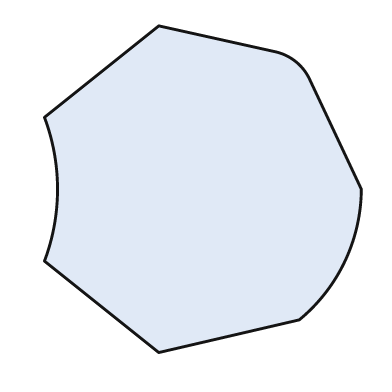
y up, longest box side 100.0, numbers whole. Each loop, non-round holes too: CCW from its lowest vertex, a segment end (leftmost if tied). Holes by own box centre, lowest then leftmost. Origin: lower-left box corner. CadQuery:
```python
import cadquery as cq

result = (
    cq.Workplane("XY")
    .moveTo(35.0, 0.0)
    .lineTo(78.0, 10.0)
    .threePointArc((92.0, 28.0), (97.0, 50.0))
    .lineTo(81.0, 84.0)
    .threePointArc((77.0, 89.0), (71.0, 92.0))
    .lineTo(35.0, 100.0)
    .lineTo(0.0, 72.0)
    .threePointArc((4.0, 50.0), (0.0, 28.0))
    .close()
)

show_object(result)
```